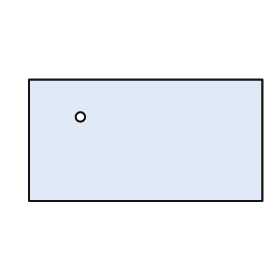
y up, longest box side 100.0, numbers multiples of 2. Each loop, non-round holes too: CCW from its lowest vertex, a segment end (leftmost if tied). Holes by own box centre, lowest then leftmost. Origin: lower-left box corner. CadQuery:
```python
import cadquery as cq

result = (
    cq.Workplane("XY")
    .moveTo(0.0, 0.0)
    .lineTo(100.0, 0.0)
    .lineTo(100.0, 52.0)
    .lineTo(0.0, 52.0)
    .close()
    .moveTo(22.0, 36.0)
    .circle(2.0)
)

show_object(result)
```